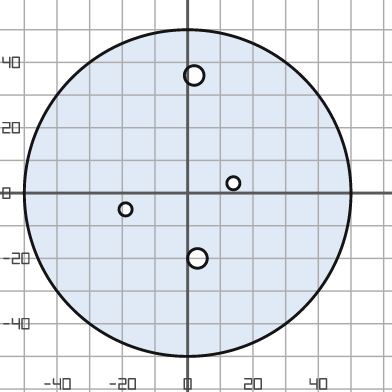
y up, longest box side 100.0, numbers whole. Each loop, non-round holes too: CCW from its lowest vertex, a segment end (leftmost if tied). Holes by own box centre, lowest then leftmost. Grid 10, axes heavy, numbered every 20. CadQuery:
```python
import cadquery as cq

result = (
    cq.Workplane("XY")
    .moveTo(0.0, 0.0)
    .circle(50.0)
    .moveTo(3.0, -20.0)
    .circle(3.0)
    .moveTo(-19.0, -5.0)
    .circle(2.0)
    .moveTo(14.0, 3.0)
    .circle(2.0)
    .moveTo(2.0, 36.0)
    .circle(3.0)
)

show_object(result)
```